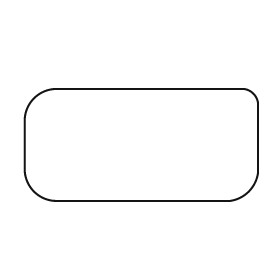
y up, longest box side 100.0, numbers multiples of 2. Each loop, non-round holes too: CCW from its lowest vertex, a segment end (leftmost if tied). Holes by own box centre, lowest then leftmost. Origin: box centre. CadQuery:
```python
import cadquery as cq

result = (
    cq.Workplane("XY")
    .moveTo(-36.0, -24.0)
    .lineTo(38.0, -24.0)
    .threePointArc((46.0, -20.0), (50.0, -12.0))
    .lineTo(50.0, 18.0)
    .threePointArc((48.0, 22.0), (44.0, 24.0))
    .lineTo(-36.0, 24.0)
    .threePointArc((-46.0, 20.0), (-50.0, 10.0))
    .lineTo(-50.0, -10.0)
    .threePointArc((-46.0, -20.0), (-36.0, -24.0))
    .close()
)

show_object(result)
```